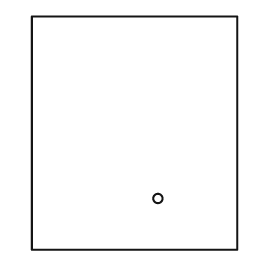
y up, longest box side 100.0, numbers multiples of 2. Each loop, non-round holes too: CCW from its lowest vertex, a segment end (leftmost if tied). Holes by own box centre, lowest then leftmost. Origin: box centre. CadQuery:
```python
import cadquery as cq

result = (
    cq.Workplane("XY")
    .moveTo(-44.0, -50.0)
    .lineTo(44.0, -50.0)
    .lineTo(44.0, 50.0)
    .lineTo(-44.0, 50.0)
    .close()
    .moveTo(10.0, -28.0)
    .circle(2.0)
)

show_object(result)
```